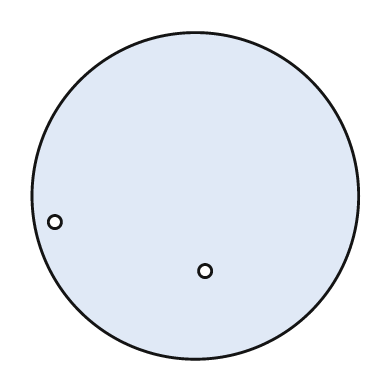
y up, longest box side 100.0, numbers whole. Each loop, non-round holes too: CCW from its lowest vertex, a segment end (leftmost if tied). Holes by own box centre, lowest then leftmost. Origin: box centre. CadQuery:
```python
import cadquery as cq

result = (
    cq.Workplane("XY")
    .moveTo(0.0, 0.0)
    .circle(50.0)
    .moveTo(3.0, -23.0)
    .circle(2.0)
    .moveTo(-43.0, -8.0)
    .circle(2.0)
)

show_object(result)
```